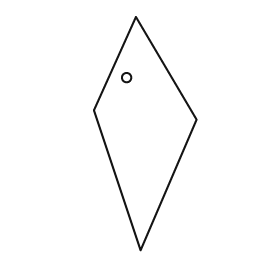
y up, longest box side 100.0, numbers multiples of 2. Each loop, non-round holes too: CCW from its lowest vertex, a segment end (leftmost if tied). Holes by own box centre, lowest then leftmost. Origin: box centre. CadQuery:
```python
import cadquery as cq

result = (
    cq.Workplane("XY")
    .moveTo(-2.0, -50.0)
    .lineTo(22.0, 6.0)
    .lineTo(-4.0, 50.0)
    .lineTo(-22.0, 10.0)
    .close()
    .moveTo(-8.0, 24.0)
    .circle(2.0)
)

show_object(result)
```